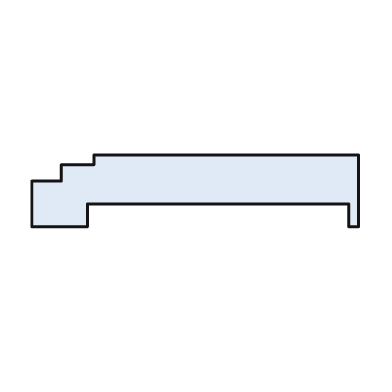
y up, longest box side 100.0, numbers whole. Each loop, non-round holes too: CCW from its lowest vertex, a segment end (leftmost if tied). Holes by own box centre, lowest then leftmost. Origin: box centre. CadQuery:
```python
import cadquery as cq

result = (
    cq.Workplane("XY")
    .moveTo(-50.0, -11.0)
    .lineTo(-33.0, -11.0)
    .lineTo(-33.0, -4.0)
    .lineTo(47.0, -4.0)
    .lineTo(47.0, -11.0)
    .lineTo(50.0, -11.0)
    .lineTo(50.0, 11.0)
    .lineTo(-31.0, 11.0)
    .lineTo(-31.0, 8.0)
    .lineTo(-41.0, 8.0)
    .lineTo(-41.0, 3.0)
    .lineTo(-50.0, 3.0)
    .close()
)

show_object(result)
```